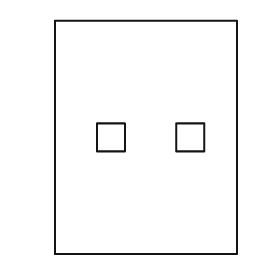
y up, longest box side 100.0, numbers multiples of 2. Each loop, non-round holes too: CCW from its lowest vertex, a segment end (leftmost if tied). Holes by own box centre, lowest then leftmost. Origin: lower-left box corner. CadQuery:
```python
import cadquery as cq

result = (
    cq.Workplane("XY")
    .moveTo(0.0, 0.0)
    .lineTo(78.0, 0.0)
    .lineTo(78.0, 100.0)
    .lineTo(0.0, 100.0)
    .close()
    .moveTo(18.0, 44.0)
    .lineTo(30.0, 44.0)
    .lineTo(30.0, 56.0)
    .lineTo(18.0, 56.0)
    .close()
    .moveTo(52.0, 44.0)
    .lineTo(64.0, 44.0)
    .lineTo(64.0, 56.0)
    .lineTo(52.0, 56.0)
    .close()
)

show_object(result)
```